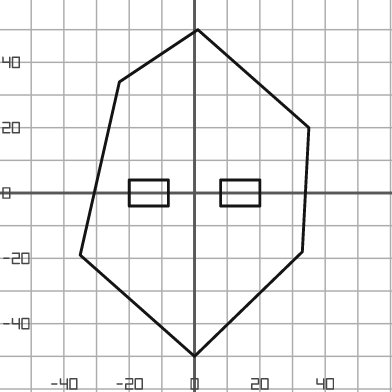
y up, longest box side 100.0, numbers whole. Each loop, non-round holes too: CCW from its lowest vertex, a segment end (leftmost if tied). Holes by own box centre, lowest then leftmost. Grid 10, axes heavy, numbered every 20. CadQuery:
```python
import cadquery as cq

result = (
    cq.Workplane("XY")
    .moveTo(0.0, -50.0)
    .lineTo(33.0, -18.0)
    .lineTo(35.0, 20.0)
    .lineTo(1.0, 50.0)
    .lineTo(-23.0, 34.0)
    .lineTo(-35.0, -19.0)
    .close()
    .moveTo(-20.0, -4.0)
    .lineTo(-8.0, -4.0)
    .lineTo(-8.0, 4.0)
    .lineTo(-20.0, 4.0)
    .close()
    .moveTo(8.0, -4.0)
    .lineTo(20.0, -4.0)
    .lineTo(20.0, 4.0)
    .lineTo(8.0, 4.0)
    .close()
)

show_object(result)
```